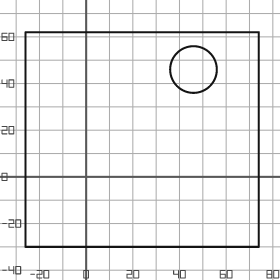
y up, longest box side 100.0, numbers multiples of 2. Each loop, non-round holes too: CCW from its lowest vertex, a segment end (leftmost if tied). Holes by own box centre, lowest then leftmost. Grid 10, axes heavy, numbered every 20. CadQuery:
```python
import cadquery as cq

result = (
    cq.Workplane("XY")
    .moveTo(-26.0, -30.0)
    .lineTo(74.0, -30.0)
    .lineTo(74.0, 62.0)
    .lineTo(-26.0, 62.0)
    .close()
    .moveTo(46.0, 46.0)
    .circle(10.0)
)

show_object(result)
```